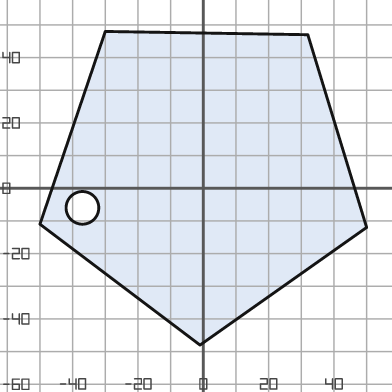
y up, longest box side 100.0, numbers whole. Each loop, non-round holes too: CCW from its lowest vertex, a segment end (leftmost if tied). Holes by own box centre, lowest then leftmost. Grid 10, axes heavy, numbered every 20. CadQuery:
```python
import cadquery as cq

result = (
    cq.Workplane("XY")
    .moveTo(-1.0, -48.0)
    .lineTo(50.0, -12.0)
    .lineTo(32.0, 47.0)
    .lineTo(-30.0, 48.0)
    .lineTo(-50.0, -11.0)
    .close()
    .moveTo(-37.0, -6.0)
    .circle(5.0)
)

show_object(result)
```